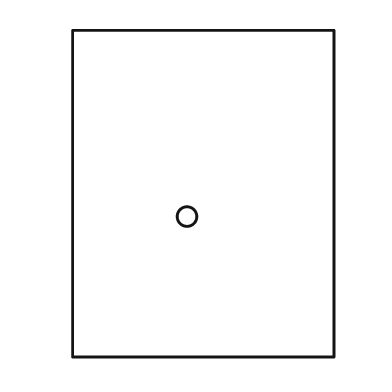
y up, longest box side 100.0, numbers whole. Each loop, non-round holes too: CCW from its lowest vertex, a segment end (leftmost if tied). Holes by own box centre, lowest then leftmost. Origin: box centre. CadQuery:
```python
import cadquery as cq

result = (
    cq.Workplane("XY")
    .moveTo(-40.0, -50.0)
    .lineTo(40.0, -50.0)
    .lineTo(40.0, 50.0)
    .lineTo(-40.0, 50.0)
    .close()
    .moveTo(-5.0, -7.0)
    .circle(3.0)
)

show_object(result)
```